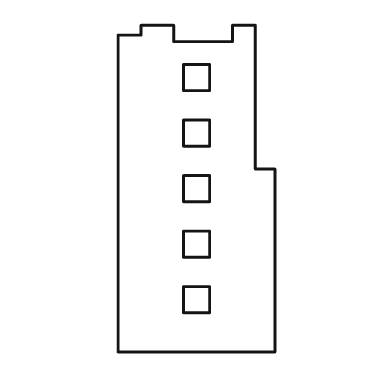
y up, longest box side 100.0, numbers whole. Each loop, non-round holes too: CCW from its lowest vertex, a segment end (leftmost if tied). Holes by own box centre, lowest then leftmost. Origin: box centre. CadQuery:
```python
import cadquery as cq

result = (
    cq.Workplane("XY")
    .moveTo(-24.0, -50.0)
    .lineTo(24.0, -50.0)
    .lineTo(24.0, 6.0)
    .lineTo(18.0, 6.0)
    .lineTo(18.0, 50.0)
    .lineTo(11.0, 50.0)
    .lineTo(11.0, 45.0)
    .lineTo(-7.0, 45.0)
    .lineTo(-7.0, 50.0)
    .lineTo(-17.0, 50.0)
    .lineTo(-17.0, 47.0)
    .lineTo(-24.0, 47.0)
    .close()
    .moveTo(-4.0, -38.0)
    .lineTo(4.0, -38.0)
    .lineTo(4.0, -30.0)
    .lineTo(-4.0, -30.0)
    .close()
    .moveTo(-4.0, -21.0)
    .lineTo(4.0, -21.0)
    .lineTo(4.0, -13.0)
    .lineTo(-4.0, -13.0)
    .close()
    .moveTo(-4.0, -4.0)
    .lineTo(4.0, -4.0)
    .lineTo(4.0, 4.0)
    .lineTo(-4.0, 4.0)
    .close()
    .moveTo(-4.0, 13.0)
    .lineTo(4.0, 13.0)
    .lineTo(4.0, 21.0)
    .lineTo(-4.0, 21.0)
    .close()
    .moveTo(-4.0, 30.0)
    .lineTo(4.0, 30.0)
    .lineTo(4.0, 38.0)
    .lineTo(-4.0, 38.0)
    .close()
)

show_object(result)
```